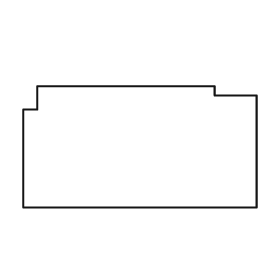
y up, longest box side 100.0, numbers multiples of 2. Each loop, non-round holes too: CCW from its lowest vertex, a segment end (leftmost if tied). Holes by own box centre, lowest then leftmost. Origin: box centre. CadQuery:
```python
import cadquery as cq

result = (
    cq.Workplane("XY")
    .moveTo(-50.0, -26.0)
    .lineTo(50.0, -26.0)
    .lineTo(50.0, 22.0)
    .lineTo(32.0, 22.0)
    .lineTo(32.0, 26.0)
    .lineTo(-44.0, 26.0)
    .lineTo(-44.0, 16.0)
    .lineTo(-50.0, 16.0)
    .close()
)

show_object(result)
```